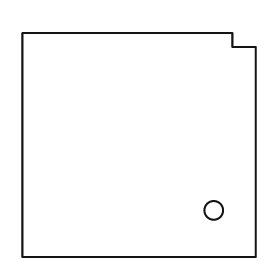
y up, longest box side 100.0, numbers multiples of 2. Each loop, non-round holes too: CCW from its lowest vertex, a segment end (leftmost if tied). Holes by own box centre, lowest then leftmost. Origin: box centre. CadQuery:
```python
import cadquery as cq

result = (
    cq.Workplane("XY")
    .moveTo(-50.0, -48.0)
    .lineTo(50.0, -48.0)
    .lineTo(50.0, 42.0)
    .lineTo(40.0, 42.0)
    .lineTo(40.0, 48.0)
    .lineTo(-50.0, 48.0)
    .close()
    .moveTo(32.0, -28.0)
    .circle(4.0)
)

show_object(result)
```